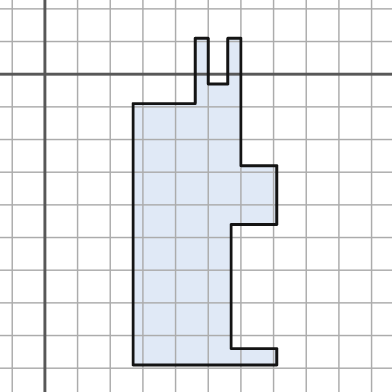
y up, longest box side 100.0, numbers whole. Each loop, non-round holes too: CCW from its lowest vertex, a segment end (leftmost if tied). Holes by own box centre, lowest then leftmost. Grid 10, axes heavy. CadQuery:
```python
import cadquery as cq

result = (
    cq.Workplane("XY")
    .moveTo(27.0, -89.0)
    .lineTo(71.0, -89.0)
    .lineTo(71.0, -84.0)
    .lineTo(57.0, -84.0)
    .lineTo(57.0, -46.0)
    .lineTo(71.0, -46.0)
    .lineTo(71.0, -28.0)
    .lineTo(60.0, -28.0)
    .lineTo(60.0, 11.0)
    .lineTo(56.0, 11.0)
    .lineTo(56.0, -3.0)
    .lineTo(50.0, -3.0)
    .lineTo(50.0, 11.0)
    .lineTo(46.0, 11.0)
    .lineTo(46.0, -9.0)
    .lineTo(27.0, -9.0)
    .close()
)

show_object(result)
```